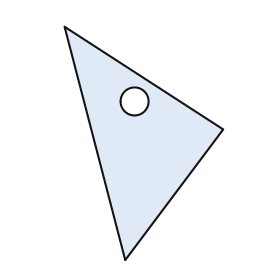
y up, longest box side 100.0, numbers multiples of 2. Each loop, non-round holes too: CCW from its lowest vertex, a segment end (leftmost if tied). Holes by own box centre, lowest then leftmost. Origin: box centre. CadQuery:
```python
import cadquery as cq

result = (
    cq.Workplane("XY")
    .moveTo(-8.0, -50.0)
    .lineTo(34.0, 6.0)
    .lineTo(-34.0, 50.0)
    .close()
    .moveTo(-4.0, 18.0)
    .circle(6.0)
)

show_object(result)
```